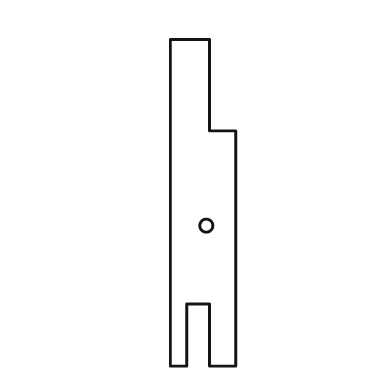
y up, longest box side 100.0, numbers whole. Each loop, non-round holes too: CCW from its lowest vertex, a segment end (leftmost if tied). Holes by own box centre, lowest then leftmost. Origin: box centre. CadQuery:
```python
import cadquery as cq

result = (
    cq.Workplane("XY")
    .moveTo(-10.0, -50.0)
    .lineTo(-5.0, -50.0)
    .lineTo(-5.0, -31.0)
    .lineTo(2.0, -31.0)
    .lineTo(2.0, -50.0)
    .lineTo(10.0, -50.0)
    .lineTo(10.0, 22.0)
    .lineTo(2.0, 22.0)
    .lineTo(2.0, 50.0)
    .lineTo(-10.0, 50.0)
    .close()
    .moveTo(1.0, -7.0)
    .circle(2.0)
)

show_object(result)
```